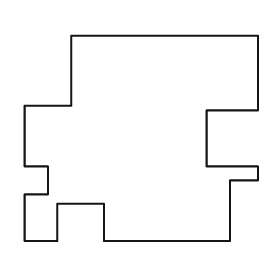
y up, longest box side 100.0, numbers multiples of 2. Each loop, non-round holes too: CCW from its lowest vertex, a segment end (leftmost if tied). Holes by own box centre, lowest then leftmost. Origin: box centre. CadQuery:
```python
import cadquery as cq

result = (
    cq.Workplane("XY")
    .moveTo(-50.0, -44.0)
    .lineTo(-36.0, -44.0)
    .lineTo(-36.0, -28.0)
    .lineTo(-16.0, -28.0)
    .lineTo(-16.0, -44.0)
    .lineTo(38.0, -44.0)
    .lineTo(38.0, -18.0)
    .lineTo(50.0, -18.0)
    .lineTo(50.0, -12.0)
    .lineTo(28.0, -12.0)
    .lineTo(28.0, 12.0)
    .lineTo(50.0, 12.0)
    .lineTo(50.0, 44.0)
    .lineTo(-30.0, 44.0)
    .lineTo(-30.0, 14.0)
    .lineTo(-50.0, 14.0)
    .lineTo(-50.0, -12.0)
    .lineTo(-40.0, -12.0)
    .lineTo(-40.0, -24.0)
    .lineTo(-50.0, -24.0)
    .close()
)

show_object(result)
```